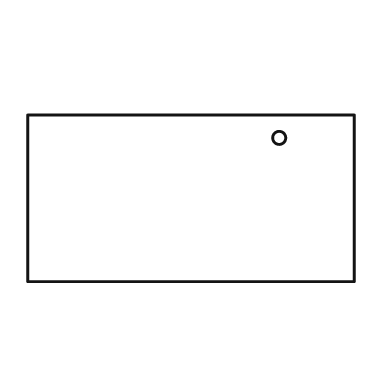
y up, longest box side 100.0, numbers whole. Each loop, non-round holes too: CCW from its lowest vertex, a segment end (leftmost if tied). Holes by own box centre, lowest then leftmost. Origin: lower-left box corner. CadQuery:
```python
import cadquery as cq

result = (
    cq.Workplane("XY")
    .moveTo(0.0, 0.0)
    .lineTo(100.0, 0.0)
    .lineTo(100.0, 51.0)
    .lineTo(0.0, 51.0)
    .close()
    .moveTo(77.0, 44.0)
    .circle(2.0)
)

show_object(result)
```